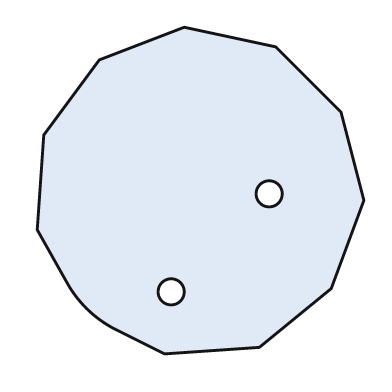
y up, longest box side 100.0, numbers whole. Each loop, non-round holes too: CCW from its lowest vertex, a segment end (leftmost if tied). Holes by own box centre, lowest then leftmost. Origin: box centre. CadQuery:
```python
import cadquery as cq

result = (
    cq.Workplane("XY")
    .moveTo(-11.0, -50.0)
    .lineTo(18.0, -48.0)
    .lineTo(40.0, -30.0)
    .lineTo(50.0, -3.0)
    .lineTo(43.0, 24.0)
    .lineTo(23.0, 44.0)
    .lineTo(-5.0, 50.0)
    .lineTo(-31.0, 40.0)
    .lineTo(-48.0, 17.0)
    .lineTo(-50.0, -12.0)
    .lineTo(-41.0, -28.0)
    .threePointArc((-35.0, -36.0), (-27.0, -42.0))
    .close()
    .moveTo(-9.0, -31.0)
    .circle(4.0)
    .moveTo(21.0, -1.0)
    .circle(4.0)
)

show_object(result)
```